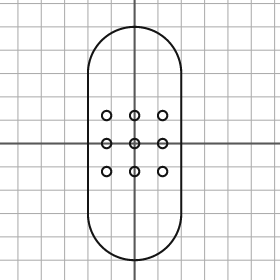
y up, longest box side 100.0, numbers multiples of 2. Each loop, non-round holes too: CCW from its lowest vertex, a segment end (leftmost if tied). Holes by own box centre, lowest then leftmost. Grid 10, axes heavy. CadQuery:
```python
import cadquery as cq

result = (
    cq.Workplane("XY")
    .moveTo(-20.0, -30.0)
    .threePointArc((0.0, -50.0), (20.0, -30.0))
    .lineTo(20.0, 30.0)
    .threePointArc((0.0, 50.0), (-20.0, 30.0))
    .close()
    .moveTo(-12.0, -12.0)
    .circle(2.0)
    .moveTo(0.0, -12.0)
    .circle(2.0)
    .moveTo(12.0, -12.0)
    .circle(2.0)
    .moveTo(-12.0, 0.0)
    .circle(2.0)
    .moveTo(0.0, 0.0)
    .circle(2.0)
    .moveTo(12.0, 0.0)
    .circle(2.0)
    .moveTo(-12.0, 12.0)
    .circle(2.0)
    .moveTo(0.0, 12.0)
    .circle(2.0)
    .moveTo(12.0, 12.0)
    .circle(2.0)
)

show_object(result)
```